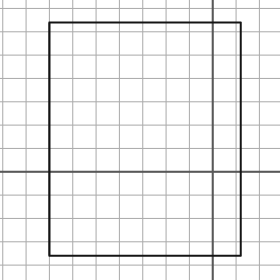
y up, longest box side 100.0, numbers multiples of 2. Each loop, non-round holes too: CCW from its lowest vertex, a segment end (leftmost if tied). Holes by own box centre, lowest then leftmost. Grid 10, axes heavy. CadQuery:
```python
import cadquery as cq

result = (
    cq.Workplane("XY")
    .moveTo(-70.0, -36.0)
    .lineTo(12.0, -36.0)
    .lineTo(12.0, 64.0)
    .lineTo(-70.0, 64.0)
    .close()
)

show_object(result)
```